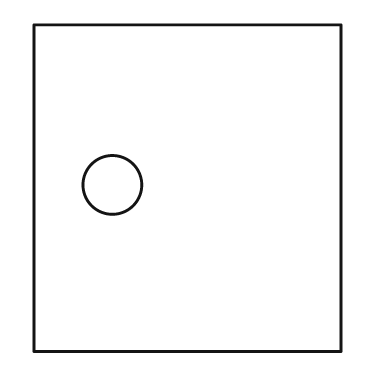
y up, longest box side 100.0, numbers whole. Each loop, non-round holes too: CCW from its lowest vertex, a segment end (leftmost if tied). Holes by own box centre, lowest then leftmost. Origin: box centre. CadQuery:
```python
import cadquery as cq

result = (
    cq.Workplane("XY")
    .moveTo(-47.0, -50.0)
    .lineTo(47.0, -50.0)
    .lineTo(47.0, 50.0)
    .lineTo(-47.0, 50.0)
    .close()
    .moveTo(-23.0, 1.0)
    .circle(9.0)
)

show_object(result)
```